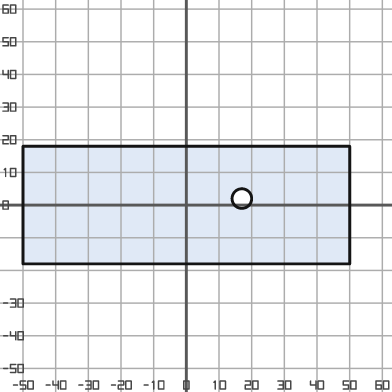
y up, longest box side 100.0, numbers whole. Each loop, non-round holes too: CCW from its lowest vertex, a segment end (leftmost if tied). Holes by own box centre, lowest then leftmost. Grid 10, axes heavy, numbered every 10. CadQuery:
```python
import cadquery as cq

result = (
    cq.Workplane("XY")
    .moveTo(-50.0, -18.0)
    .lineTo(50.0, -18.0)
    .lineTo(50.0, 18.0)
    .lineTo(-50.0, 18.0)
    .close()
    .moveTo(17.0, 2.0)
    .circle(3.0)
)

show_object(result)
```